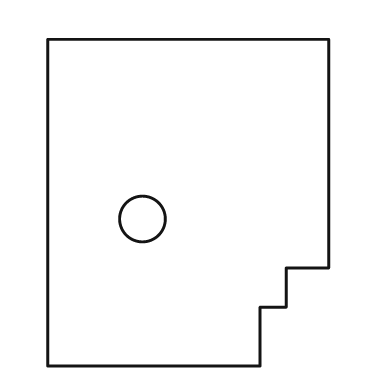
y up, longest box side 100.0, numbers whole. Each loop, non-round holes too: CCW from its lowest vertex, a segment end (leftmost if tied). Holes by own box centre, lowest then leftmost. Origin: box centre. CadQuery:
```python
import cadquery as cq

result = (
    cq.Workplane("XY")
    .moveTo(-43.0, -50.0)
    .lineTo(22.0, -50.0)
    .lineTo(22.0, -32.0)
    .lineTo(30.0, -32.0)
    .lineTo(30.0, -20.0)
    .lineTo(43.0, -20.0)
    .lineTo(43.0, 50.0)
    .lineTo(-43.0, 50.0)
    .close()
    .moveTo(-14.0, -5.0)
    .circle(7.0)
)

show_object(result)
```